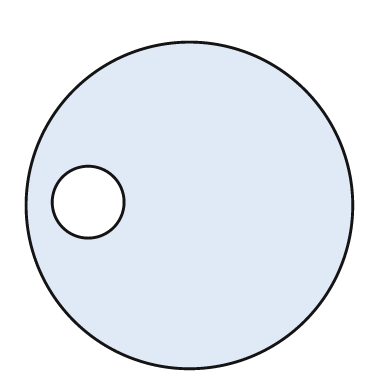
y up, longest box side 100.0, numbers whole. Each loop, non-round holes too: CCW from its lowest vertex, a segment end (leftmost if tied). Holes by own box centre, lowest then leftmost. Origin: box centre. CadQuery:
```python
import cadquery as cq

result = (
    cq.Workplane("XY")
    .moveTo(0.0, 0.0)
    .circle(50.0)
    .moveTo(-31.0, 1.0)
    .circle(11.0)
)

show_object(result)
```